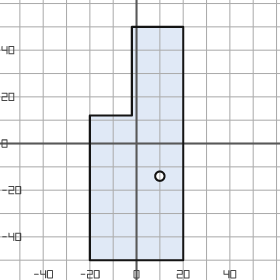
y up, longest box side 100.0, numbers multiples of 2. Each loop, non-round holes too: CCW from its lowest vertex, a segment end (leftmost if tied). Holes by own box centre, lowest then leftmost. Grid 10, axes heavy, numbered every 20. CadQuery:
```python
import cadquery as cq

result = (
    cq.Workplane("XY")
    .moveTo(-20.0, -50.0)
    .lineTo(20.0, -50.0)
    .lineTo(20.0, 50.0)
    .lineTo(-2.0, 50.0)
    .lineTo(-2.0, 12.0)
    .lineTo(-20.0, 12.0)
    .close()
    .moveTo(10.0, -14.0)
    .circle(2.0)
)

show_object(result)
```